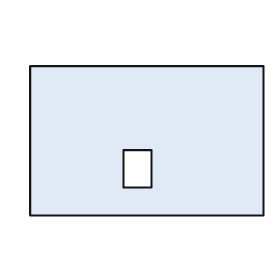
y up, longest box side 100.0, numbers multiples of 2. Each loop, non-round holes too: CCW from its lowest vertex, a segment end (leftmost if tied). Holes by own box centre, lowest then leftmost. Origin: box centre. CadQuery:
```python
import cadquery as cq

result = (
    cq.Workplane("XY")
    .moveTo(-50.0, -32.0)
    .lineTo(50.0, -32.0)
    .lineTo(50.0, 32.0)
    .lineTo(-50.0, 32.0)
    .close()
    .moveTo(-10.0, -20.0)
    .lineTo(2.0, -20.0)
    .lineTo(2.0, -4.0)
    .lineTo(-10.0, -4.0)
    .close()
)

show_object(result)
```